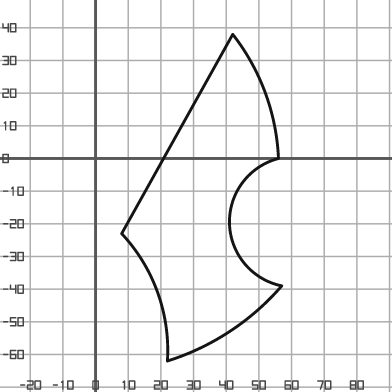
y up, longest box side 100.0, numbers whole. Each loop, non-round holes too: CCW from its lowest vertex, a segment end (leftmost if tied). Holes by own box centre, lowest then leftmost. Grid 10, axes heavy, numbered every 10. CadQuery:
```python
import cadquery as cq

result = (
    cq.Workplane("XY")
    .moveTo(22.0, -62.0)
    .threePointArc((41.0, -53.0), (57.0, -39.0))
    .threePointArc((41.0, -20.0), (56.0, 0.0))
    .threePointArc((52.0, 20.0), (42.0, 38.0))
    .lineTo(8.0, -23.0)
    .threePointArc((19.0, -41.0), (22.0, -62.0))
    .close()
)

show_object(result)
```